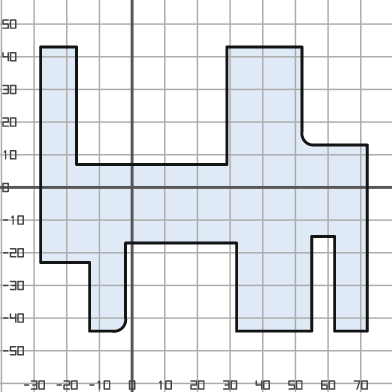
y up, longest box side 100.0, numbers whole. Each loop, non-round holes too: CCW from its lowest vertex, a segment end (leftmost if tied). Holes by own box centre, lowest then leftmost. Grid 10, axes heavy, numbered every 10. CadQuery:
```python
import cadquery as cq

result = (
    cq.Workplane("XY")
    .moveTo(-13.0, -44.0)
    .lineTo(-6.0, -44.0)
    .threePointArc((-3.0, -43.0), (-2.0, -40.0))
    .lineTo(-2.0, -17.0)
    .lineTo(32.0, -17.0)
    .lineTo(32.0, -44.0)
    .lineTo(55.0, -44.0)
    .lineTo(55.0, -15.0)
    .lineTo(62.0, -15.0)
    .lineTo(62.0, -44.0)
    .lineTo(72.0, -44.0)
    .lineTo(72.0, 13.0)
    .lineTo(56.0, 13.0)
    .threePointArc((53.0, 14.0), (52.0, 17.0))
    .lineTo(52.0, 43.0)
    .lineTo(29.0, 43.0)
    .lineTo(29.0, 7.0)
    .lineTo(-17.0, 7.0)
    .lineTo(-17.0, 43.0)
    .lineTo(-28.0, 43.0)
    .lineTo(-28.0, -23.0)
    .lineTo(-13.0, -23.0)
    .close()
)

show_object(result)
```